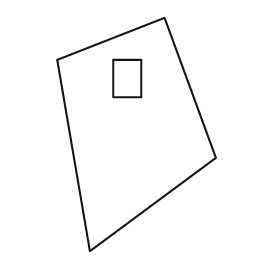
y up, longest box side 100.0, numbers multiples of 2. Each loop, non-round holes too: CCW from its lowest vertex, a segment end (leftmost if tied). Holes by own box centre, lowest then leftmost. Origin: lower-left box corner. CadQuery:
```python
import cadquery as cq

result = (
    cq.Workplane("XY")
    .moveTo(14.0, 0.0)
    .lineTo(68.0, 40.0)
    .lineTo(46.0, 100.0)
    .lineTo(0.0, 82.0)
    .close()
    .moveTo(24.0, 66.0)
    .lineTo(36.0, 66.0)
    .lineTo(36.0, 82.0)
    .lineTo(24.0, 82.0)
    .close()
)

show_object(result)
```